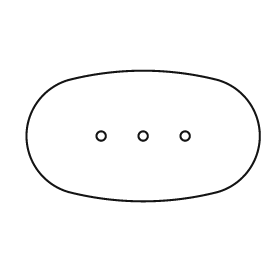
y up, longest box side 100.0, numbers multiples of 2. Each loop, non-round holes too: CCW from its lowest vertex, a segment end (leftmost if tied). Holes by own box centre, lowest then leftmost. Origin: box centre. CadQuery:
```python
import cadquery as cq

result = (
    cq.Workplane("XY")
    .moveTo(-32.0, -24.0)
    .threePointArc((0.0, -28.0), (32.0, -24.0))
    .threePointArc((50.0, 0.0), (32.0, 24.0))
    .threePointArc((0.0, 28.0), (-32.0, 24.0))
    .threePointArc((-50.0, 0.0), (-32.0, -24.0))
    .close()
    .moveTo(-18.0, 0.0)
    .circle(2.0)
    .moveTo(0.0, 0.0)
    .circle(2.0)
    .moveTo(18.0, 0.0)
    .circle(2.0)
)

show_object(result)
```